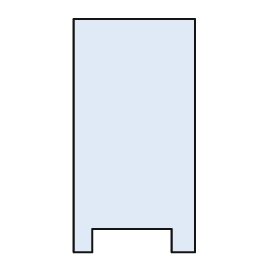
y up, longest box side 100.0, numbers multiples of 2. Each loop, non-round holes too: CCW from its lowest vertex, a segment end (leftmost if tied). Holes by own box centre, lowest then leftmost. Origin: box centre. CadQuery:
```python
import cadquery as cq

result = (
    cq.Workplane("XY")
    .moveTo(-26.0, -50.0)
    .lineTo(-18.0, -50.0)
    .lineTo(-18.0, -40.0)
    .lineTo(16.0, -40.0)
    .lineTo(16.0, -50.0)
    .lineTo(26.0, -50.0)
    .lineTo(26.0, 50.0)
    .lineTo(-26.0, 50.0)
    .close()
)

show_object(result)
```